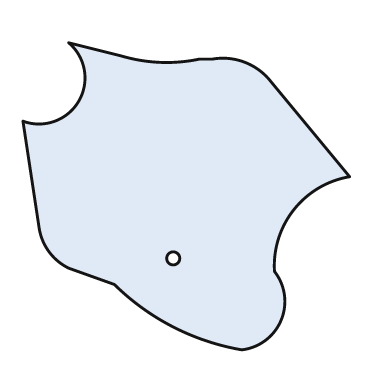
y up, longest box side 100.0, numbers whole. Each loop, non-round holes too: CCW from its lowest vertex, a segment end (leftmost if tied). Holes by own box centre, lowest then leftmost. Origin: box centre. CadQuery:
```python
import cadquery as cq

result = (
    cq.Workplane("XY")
    .moveTo(17.0, -47.0)
    .threePointArc((29.0, -38.0), (27.0, -23.0))
    .threePointArc((33.0, -4.0), (50.0, 6.0))
    .lineTo(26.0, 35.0)
    .threePointArc((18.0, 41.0), (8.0, 42.0))
    .lineTo(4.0, 42.0)
    .threePointArc((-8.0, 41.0), (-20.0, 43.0))
    .lineTo(-36.0, 47.0)
    .threePointArc((-33.0, 29.0), (-50.0, 23.0))
    .lineTo(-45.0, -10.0)
    .threePointArc((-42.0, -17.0), (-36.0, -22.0))
    .lineTo(-22.0, -27.0)
    .threePointArc((-4.0, -40.0), (17.0, -47.0))
    .close()
    .moveTo(-4.0, -19.0)
    .circle(2.0)
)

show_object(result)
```